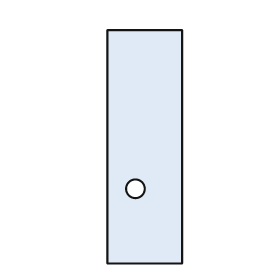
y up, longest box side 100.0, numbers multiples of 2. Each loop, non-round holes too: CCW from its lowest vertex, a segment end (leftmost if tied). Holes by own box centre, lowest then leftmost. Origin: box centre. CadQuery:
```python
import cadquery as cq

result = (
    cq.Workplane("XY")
    .moveTo(-16.0, -50.0)
    .lineTo(16.0, -50.0)
    .lineTo(16.0, 50.0)
    .lineTo(-16.0, 50.0)
    .close()
    .moveTo(-4.0, -18.0)
    .circle(4.0)
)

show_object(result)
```